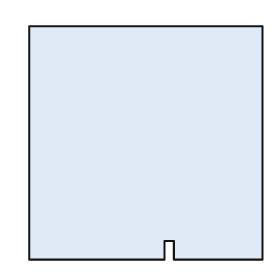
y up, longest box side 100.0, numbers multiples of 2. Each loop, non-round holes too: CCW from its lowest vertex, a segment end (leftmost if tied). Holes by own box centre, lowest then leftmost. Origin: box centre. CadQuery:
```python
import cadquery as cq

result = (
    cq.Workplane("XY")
    .moveTo(-50.0, -50.0)
    .lineTo(8.0, -50.0)
    .lineTo(8.0, -42.0)
    .lineTo(12.0, -42.0)
    .lineTo(12.0, -50.0)
    .lineTo(50.0, -50.0)
    .lineTo(50.0, 50.0)
    .lineTo(-50.0, 50.0)
    .close()
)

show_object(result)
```